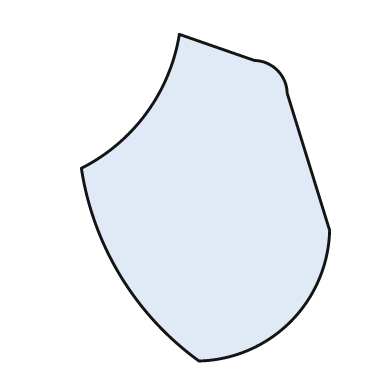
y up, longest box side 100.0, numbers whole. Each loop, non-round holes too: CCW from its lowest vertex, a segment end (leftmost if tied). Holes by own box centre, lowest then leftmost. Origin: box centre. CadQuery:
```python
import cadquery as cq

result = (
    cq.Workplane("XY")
    .moveTo(-2.0, -50.0)
    .threePointArc((26.0, -38.0), (38.0, -10.0))
    .lineTo(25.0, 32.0)
    .threePointArc((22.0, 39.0), (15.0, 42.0))
    .lineTo(-8.0, 50.0)
    .threePointArc((-18.0, 26.0), (-38.0, 9.0))
    .threePointArc((-26.0, -24.0), (-2.0, -50.0))
    .close()
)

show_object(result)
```